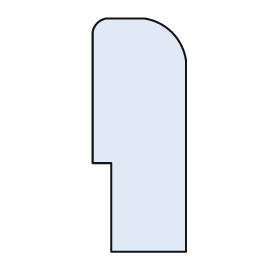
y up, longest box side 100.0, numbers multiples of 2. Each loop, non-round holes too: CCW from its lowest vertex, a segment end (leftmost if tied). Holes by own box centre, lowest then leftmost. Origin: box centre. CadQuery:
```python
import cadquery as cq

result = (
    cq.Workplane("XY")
    .moveTo(-12.0, -50.0)
    .lineTo(20.0, -50.0)
    .lineTo(20.0, 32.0)
    .threePointArc((14.0, 44.0), (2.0, 50.0))
    .lineTo(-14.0, 50.0)
    .threePointArc((-18.0, 48.0), (-20.0, 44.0))
    .lineTo(-20.0, -12.0)
    .lineTo(-12.0, -12.0)
    .close()
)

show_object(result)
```